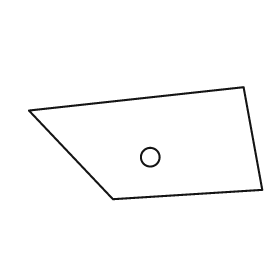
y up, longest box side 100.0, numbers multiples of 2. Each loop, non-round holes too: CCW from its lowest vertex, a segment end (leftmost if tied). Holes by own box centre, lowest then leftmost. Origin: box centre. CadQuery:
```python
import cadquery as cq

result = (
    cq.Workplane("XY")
    .moveTo(-14.0, -24.0)
    .lineTo(50.0, -20.0)
    .lineTo(42.0, 24.0)
    .lineTo(-50.0, 14.0)
    .close()
    .moveTo(2.0, -6.0)
    .circle(4.0)
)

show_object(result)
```